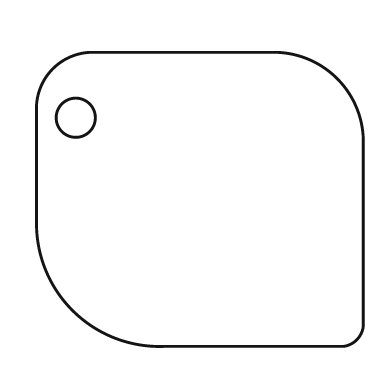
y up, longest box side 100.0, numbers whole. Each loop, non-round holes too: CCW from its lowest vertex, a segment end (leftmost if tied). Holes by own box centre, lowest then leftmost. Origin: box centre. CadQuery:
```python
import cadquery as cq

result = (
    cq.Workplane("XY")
    .moveTo(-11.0, -45.0)
    .lineTo(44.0, -45.0)
    .threePointArc((48.0, -43.0), (50.0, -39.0))
    .lineTo(50.0, 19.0)
    .threePointArc((42.0, 37.0), (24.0, 45.0))
    .lineTo(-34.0, 45.0)
    .threePointArc((-45.0, 40.0), (-50.0, 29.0))
    .lineTo(-50.0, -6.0)
    .threePointArc((-39.0, -34.0), (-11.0, -45.0))
    .close()
    .moveTo(-38.0, 25.0)
    .circle(6.0)
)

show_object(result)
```